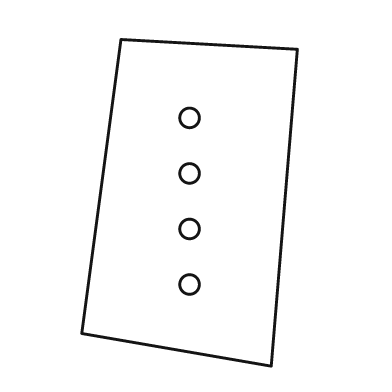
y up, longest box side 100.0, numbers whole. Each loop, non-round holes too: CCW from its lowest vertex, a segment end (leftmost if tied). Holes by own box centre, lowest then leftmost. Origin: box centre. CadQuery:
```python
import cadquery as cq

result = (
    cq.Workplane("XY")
    .moveTo(25.0, -50.0)
    .lineTo(33.0, 47.0)
    .lineTo(-21.0, 50.0)
    .lineTo(-33.0, -40.0)
    .close()
    .moveTo(0.0, -25.0)
    .circle(3.0)
    .moveTo(0.0, -8.0)
    .circle(3.0)
    .moveTo(0.0, 9.0)
    .circle(3.0)
    .moveTo(0.0, 26.0)
    .circle(3.0)
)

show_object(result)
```